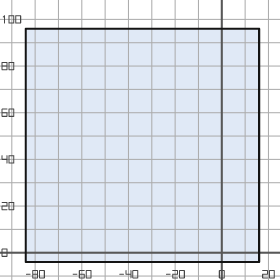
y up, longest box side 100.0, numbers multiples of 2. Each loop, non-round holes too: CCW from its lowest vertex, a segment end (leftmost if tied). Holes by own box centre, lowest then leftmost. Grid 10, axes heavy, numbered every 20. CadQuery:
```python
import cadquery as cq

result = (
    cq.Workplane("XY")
    .moveTo(-84.0, -4.0)
    .lineTo(16.0, -4.0)
    .lineTo(16.0, 96.0)
    .lineTo(-84.0, 96.0)
    .close()
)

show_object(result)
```